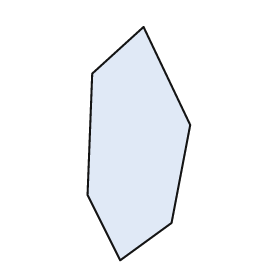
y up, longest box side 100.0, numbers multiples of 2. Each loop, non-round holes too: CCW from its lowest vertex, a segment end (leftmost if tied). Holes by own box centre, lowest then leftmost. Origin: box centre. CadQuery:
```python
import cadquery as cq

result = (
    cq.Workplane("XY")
    .moveTo(-8.0, -50.0)
    .lineTo(14.0, -34.0)
    .lineTo(22.0, 8.0)
    .lineTo(2.0, 50.0)
    .lineTo(-20.0, 30.0)
    .lineTo(-22.0, -22.0)
    .close()
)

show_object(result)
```